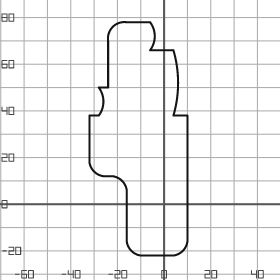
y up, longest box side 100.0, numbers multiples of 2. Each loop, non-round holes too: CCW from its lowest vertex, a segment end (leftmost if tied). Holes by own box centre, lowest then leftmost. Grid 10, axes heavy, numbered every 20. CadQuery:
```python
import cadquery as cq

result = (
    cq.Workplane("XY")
    .moveTo(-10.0, -22.0)
    .lineTo(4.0, -22.0)
    .threePointArc((8.0, -20.0), (10.0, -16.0))
    .lineTo(10.0, 38.0)
    .lineTo(4.0, 38.0)
    .threePointArc((6.0, 52.0), (4.0, 66.0))
    .lineTo(-6.0, 66.0)
    .threePointArc((-4.0, 72.0), (-6.0, 78.0))
    .lineTo(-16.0, 78.0)
    .threePointArc((-22.0, 76.0), (-24.0, 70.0))
    .lineTo(-24.0, 50.0)
    .lineTo(-28.0, 50.0)
    .threePointArc((-26.0, 44.0), (-28.0, 38.0))
    .lineTo(-32.0, 38.0)
    .lineTo(-32.0, 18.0)
    .threePointArc((-30.0, 14.0), (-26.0, 12.0))
    .lineTo(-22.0, 12.0)
    .threePointArc((-18.0, 10.0), (-16.0, 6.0))
    .lineTo(-16.0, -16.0)
    .threePointArc((-14.0, -20.0), (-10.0, -22.0))
    .close()
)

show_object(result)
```